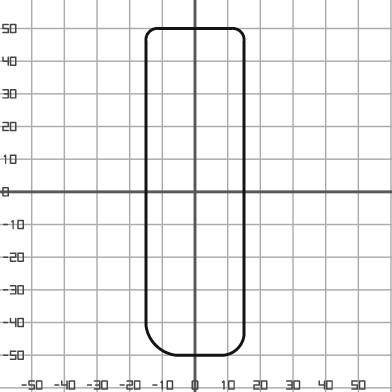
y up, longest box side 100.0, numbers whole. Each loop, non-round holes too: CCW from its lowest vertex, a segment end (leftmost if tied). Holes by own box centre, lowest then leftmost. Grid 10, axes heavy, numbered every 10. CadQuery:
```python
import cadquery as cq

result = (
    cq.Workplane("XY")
    .moveTo(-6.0, -50.0)
    .lineTo(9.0, -50.0)
    .threePointArc((13.0, -48.0), (15.0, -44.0))
    .lineTo(15.0, 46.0)
    .threePointArc((14.0, 49.0), (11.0, 50.0))
    .lineTo(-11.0, 50.0)
    .threePointArc((-14.0, 49.0), (-15.0, 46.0))
    .lineTo(-15.0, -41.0)
    .threePointArc((-12.0, -47.0), (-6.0, -50.0))
    .close()
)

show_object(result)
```